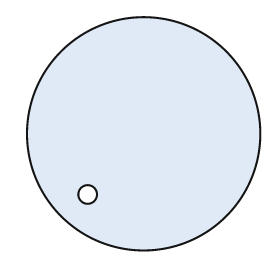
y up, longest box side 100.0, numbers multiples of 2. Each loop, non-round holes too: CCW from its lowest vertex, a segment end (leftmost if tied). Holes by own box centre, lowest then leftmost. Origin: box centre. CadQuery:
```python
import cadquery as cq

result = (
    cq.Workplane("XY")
    .moveTo(0.0, 0.0)
    .circle(50.0)
    .moveTo(-24.0, -26.0)
    .circle(4.0)
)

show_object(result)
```